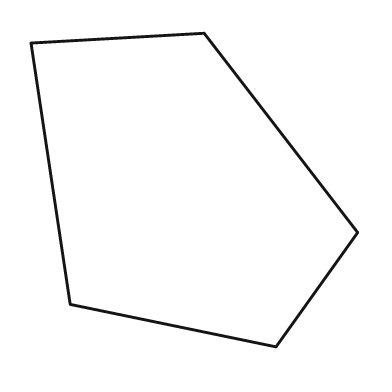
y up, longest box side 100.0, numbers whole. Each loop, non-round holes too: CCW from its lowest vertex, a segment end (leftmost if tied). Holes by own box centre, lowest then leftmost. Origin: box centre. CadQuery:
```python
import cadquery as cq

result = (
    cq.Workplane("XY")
    .moveTo(25.0, -48.0)
    .lineTo(50.0, -13.0)
    .lineTo(3.0, 48.0)
    .lineTo(-50.0, 45.0)
    .lineTo(-38.0, -35.0)
    .close()
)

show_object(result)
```